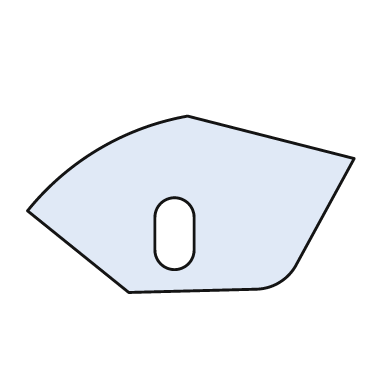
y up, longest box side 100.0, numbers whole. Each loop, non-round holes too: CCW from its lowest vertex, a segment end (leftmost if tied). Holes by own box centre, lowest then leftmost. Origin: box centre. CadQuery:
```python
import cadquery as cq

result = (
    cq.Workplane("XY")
    .moveTo(-19.0, -27.0)
    .lineTo(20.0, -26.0)
    .threePointArc((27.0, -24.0), (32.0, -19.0))
    .lineTo(50.0, 14.0)
    .lineTo(-1.0, 27.0)
    .threePointArc((-28.0, 17.0), (-50.0, -2.0))
    .close()
    .moveTo(-11.0, -14.0)
    .threePointArc((-5.0, -20.0), (1.0, -14.0))
    .lineTo(1.0, -4.0)
    .threePointArc((-5.0, 2.0), (-11.0, -4.0))
    .close()
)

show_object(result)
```